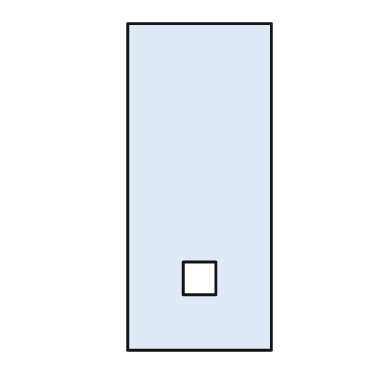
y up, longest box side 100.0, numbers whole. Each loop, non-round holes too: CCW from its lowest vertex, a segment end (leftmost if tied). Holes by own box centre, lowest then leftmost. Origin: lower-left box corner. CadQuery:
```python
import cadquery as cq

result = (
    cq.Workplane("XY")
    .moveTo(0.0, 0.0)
    .lineTo(44.0, 0.0)
    .lineTo(44.0, 100.0)
    .lineTo(0.0, 100.0)
    .close()
    .moveTo(17.0, 17.0)
    .lineTo(27.0, 17.0)
    .lineTo(27.0, 27.0)
    .lineTo(17.0, 27.0)
    .close()
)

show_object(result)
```